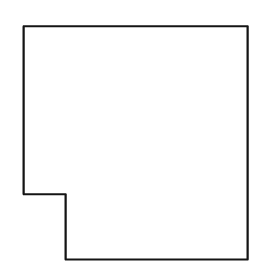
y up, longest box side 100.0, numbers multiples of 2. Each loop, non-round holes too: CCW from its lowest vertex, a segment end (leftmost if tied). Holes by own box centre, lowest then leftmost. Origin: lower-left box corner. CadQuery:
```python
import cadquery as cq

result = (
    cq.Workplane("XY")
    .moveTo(18.0, 0.0)
    .lineTo(96.0, 0.0)
    .lineTo(96.0, 100.0)
    .lineTo(0.0, 100.0)
    .lineTo(0.0, 28.0)
    .lineTo(18.0, 28.0)
    .close()
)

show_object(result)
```